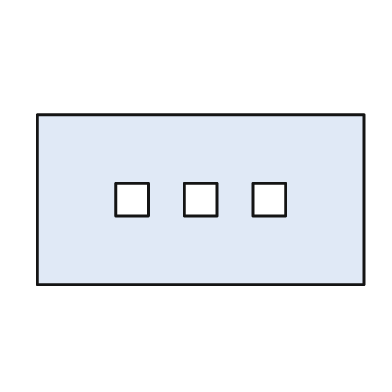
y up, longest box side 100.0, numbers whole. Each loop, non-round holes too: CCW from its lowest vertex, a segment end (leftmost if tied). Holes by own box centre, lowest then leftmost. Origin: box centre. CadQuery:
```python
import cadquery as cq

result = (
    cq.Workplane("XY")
    .moveTo(-50.0, -26.0)
    .lineTo(50.0, -26.0)
    .lineTo(50.0, 26.0)
    .lineTo(-50.0, 26.0)
    .close()
    .moveTo(-26.0, -5.0)
    .lineTo(-16.0, -5.0)
    .lineTo(-16.0, 5.0)
    .lineTo(-26.0, 5.0)
    .close()
    .moveTo(-5.0, -5.0)
    .lineTo(5.0, -5.0)
    .lineTo(5.0, 5.0)
    .lineTo(-5.0, 5.0)
    .close()
    .moveTo(16.0, -5.0)
    .lineTo(26.0, -5.0)
    .lineTo(26.0, 5.0)
    .lineTo(16.0, 5.0)
    .close()
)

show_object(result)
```